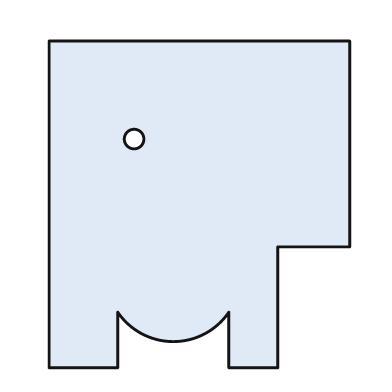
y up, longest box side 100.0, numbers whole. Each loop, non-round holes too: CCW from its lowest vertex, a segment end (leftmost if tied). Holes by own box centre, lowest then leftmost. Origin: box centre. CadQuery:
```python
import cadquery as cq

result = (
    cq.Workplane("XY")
    .moveTo(-46.0, -50.0)
    .lineTo(-25.0, -50.0)
    .lineTo(-25.0, -33.0)
    .threePointArc((-8.0, -42.0), (9.0, -33.0))
    .lineTo(9.0, -50.0)
    .lineTo(24.0, -50.0)
    .lineTo(24.0, -13.0)
    .lineTo(46.0, -13.0)
    .lineTo(46.0, 50.0)
    .lineTo(-46.0, 50.0)
    .close()
    .moveTo(-20.0, 20.0)
    .circle(3.0)
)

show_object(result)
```